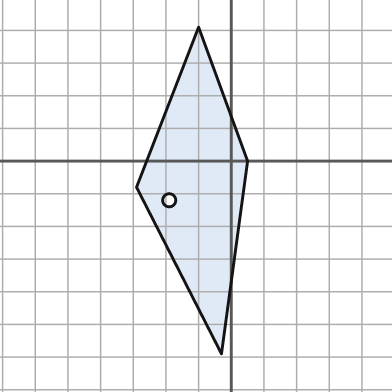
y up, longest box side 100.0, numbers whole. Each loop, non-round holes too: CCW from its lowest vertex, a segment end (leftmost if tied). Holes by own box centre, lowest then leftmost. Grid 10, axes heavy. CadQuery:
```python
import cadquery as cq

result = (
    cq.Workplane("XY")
    .moveTo(-3.0, -59.0)
    .lineTo(5.0, 0.0)
    .lineTo(-10.0, 41.0)
    .lineTo(-29.0, -8.0)
    .close()
    .moveTo(-19.0, -12.0)
    .circle(2.0)
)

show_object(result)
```